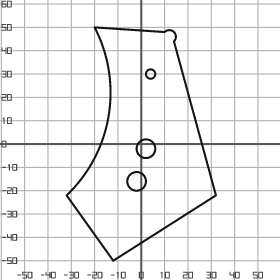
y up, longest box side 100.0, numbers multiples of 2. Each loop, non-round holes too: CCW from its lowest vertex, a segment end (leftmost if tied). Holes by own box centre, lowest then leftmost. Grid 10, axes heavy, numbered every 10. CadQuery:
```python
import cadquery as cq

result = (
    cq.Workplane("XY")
    .moveTo(-12.0, -50.0)
    .lineTo(32.0, -22.0)
    .lineTo(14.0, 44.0)
    .threePointArc((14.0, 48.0), (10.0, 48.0))
    .lineTo(-20.0, 50.0)
    .threePointArc((-14.0, 12.0), (-32.0, -22.0))
    .close()
    .moveTo(-2.0, -16.0)
    .circle(4.0)
    .moveTo(2.0, -2.0)
    .circle(4.0)
    .moveTo(4.0, 30.0)
    .circle(2.0)
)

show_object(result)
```